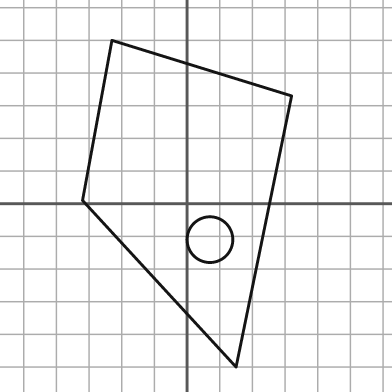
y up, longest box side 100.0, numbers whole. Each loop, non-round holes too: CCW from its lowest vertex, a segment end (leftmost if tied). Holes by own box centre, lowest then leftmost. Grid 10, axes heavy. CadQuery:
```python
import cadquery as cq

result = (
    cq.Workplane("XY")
    .moveTo(15.0, -50.0)
    .lineTo(32.0, 33.0)
    .lineTo(-23.0, 50.0)
    .lineTo(-32.0, 1.0)
    .close()
    .moveTo(7.0, -11.0)
    .circle(7.0)
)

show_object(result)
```